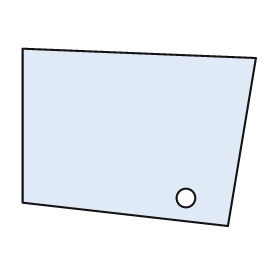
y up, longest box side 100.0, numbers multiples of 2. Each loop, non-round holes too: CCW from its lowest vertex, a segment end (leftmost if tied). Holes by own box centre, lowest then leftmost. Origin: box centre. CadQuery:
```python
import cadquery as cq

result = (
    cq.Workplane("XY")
    .moveTo(38.0, -38.0)
    .lineTo(50.0, 34.0)
    .lineTo(-50.0, 38.0)
    .lineTo(-50.0, -28.0)
    .close()
    .moveTo(20.0, -26.0)
    .circle(4.0)
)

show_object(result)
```